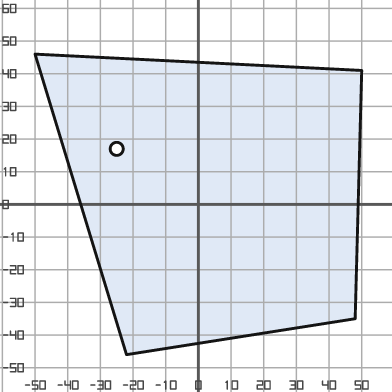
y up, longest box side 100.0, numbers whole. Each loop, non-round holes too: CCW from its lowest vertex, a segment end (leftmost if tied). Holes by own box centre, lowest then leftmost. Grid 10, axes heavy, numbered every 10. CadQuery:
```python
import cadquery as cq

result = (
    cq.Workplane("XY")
    .moveTo(-22.0, -46.0)
    .lineTo(48.0, -35.0)
    .lineTo(50.0, 41.0)
    .lineTo(-50.0, 46.0)
    .close()
    .moveTo(-25.0, 17.0)
    .circle(2.0)
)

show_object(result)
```